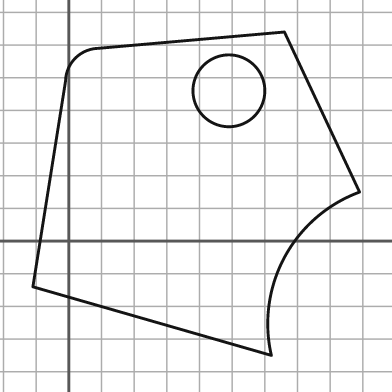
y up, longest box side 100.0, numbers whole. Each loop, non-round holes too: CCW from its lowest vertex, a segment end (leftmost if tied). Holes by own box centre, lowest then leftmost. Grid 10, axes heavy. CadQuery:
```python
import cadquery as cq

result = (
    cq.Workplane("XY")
    .moveTo(62.0, -35.0)
    .threePointArc((66.0, -5.0), (89.0, 15.0))
    .lineTo(66.0, 64.0)
    .lineTo(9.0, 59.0)
    .threePointArc((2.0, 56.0), (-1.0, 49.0))
    .lineTo(-11.0, -14.0)
    .close()
    .moveTo(49.0, 46.0)
    .circle(11.0)
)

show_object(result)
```